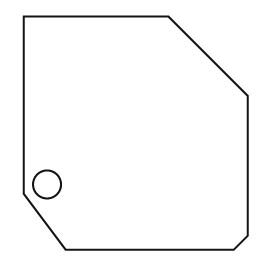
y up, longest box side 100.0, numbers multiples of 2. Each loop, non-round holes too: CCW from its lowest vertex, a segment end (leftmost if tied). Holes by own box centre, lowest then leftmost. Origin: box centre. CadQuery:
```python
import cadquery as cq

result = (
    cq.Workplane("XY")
    .moveTo(-30.0, -50.0)
    .lineTo(42.0, -50.0)
    .lineTo(48.0, -44.0)
    .lineTo(48.0, 16.0)
    .lineTo(14.0, 50.0)
    .lineTo(-48.0, 50.0)
    .lineTo(-48.0, -26.0)
    .close()
    .moveTo(-38.0, -22.0)
    .circle(6.0)
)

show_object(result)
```